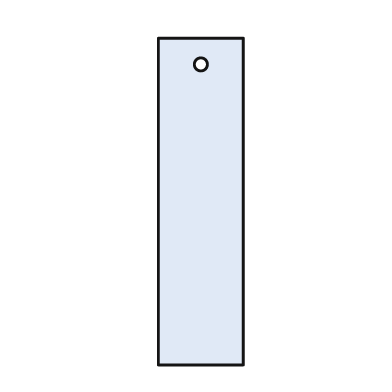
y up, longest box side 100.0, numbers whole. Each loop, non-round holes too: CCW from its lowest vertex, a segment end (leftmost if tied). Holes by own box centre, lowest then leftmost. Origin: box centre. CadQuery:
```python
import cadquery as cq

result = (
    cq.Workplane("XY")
    .moveTo(-13.0, -50.0)
    .lineTo(13.0, -50.0)
    .lineTo(13.0, 50.0)
    .lineTo(-13.0, 50.0)
    .close()
    .moveTo(0.0, 42.0)
    .circle(2.0)
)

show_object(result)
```